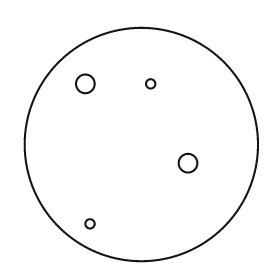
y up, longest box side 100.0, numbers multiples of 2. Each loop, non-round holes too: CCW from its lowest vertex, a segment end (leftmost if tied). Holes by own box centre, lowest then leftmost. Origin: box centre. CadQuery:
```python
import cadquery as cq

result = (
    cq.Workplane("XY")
    .moveTo(0.0, 0.0)
    .circle(50.0)
    .moveTo(-22.0, -34.0)
    .circle(2.0)
    .moveTo(20.0, -8.0)
    .circle(4.0)
    .moveTo(-24.0, 26.0)
    .circle(4.0)
    .moveTo(4.0, 26.0)
    .circle(2.0)
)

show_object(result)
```